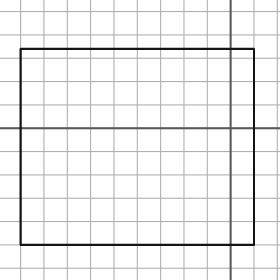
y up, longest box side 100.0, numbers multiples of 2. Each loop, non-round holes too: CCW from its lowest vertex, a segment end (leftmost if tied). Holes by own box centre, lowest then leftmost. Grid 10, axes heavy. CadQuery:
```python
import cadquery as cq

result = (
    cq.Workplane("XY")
    .moveTo(-90.0, -50.0)
    .lineTo(10.0, -50.0)
    .lineTo(10.0, 34.0)
    .lineTo(-90.0, 34.0)
    .close()
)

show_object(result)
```